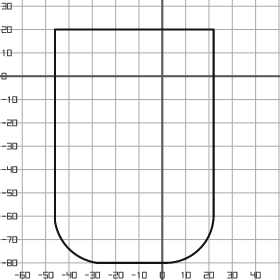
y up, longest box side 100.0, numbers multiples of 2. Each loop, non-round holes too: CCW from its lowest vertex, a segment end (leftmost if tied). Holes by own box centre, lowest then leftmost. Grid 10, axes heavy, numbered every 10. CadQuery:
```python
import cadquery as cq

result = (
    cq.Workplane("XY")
    .moveTo(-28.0, -80.0)
    .lineTo(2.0, -80.0)
    .threePointArc((16.0, -74.0), (22.0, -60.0))
    .lineTo(22.0, 20.0)
    .lineTo(-46.0, 20.0)
    .lineTo(-46.0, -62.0)
    .threePointArc((-40.0, -74.0), (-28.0, -80.0))
    .close()
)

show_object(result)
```